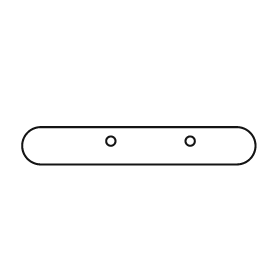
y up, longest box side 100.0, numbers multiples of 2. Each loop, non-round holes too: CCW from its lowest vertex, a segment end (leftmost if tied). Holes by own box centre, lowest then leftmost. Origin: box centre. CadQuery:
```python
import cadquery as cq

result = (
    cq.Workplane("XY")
    .moveTo(-42.0, -8.0)
    .lineTo(42.0, -8.0)
    .threePointArc((50.0, 0.0), (42.0, 8.0))
    .lineTo(-42.0, 8.0)
    .threePointArc((-50.0, 0.0), (-42.0, -8.0))
    .close()
    .moveTo(-12.0, 2.0)
    .circle(2.0)
    .moveTo(22.0, 2.0)
    .circle(2.0)
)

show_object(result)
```